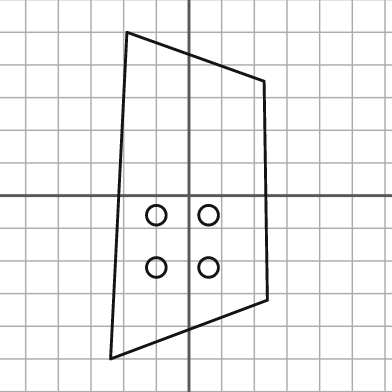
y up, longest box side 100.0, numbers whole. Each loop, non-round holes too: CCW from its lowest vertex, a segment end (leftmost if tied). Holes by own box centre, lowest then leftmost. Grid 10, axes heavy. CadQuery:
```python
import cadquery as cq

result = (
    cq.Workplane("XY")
    .moveTo(-24.0, -50.0)
    .lineTo(24.0, -32.0)
    .lineTo(23.0, 35.0)
    .lineTo(-19.0, 50.0)
    .close()
    .moveTo(-10.0, -22.0)
    .circle(3.0)
    .moveTo(6.0, -22.0)
    .circle(3.0)
    .moveTo(-10.0, -6.0)
    .circle(3.0)
    .moveTo(6.0, -6.0)
    .circle(3.0)
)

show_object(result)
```